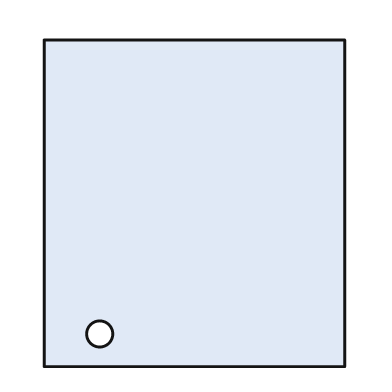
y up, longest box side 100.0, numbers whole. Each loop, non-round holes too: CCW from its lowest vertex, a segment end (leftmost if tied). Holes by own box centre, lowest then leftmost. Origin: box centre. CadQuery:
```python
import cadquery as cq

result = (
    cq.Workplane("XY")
    .moveTo(-46.0, -50.0)
    .lineTo(46.0, -50.0)
    .lineTo(46.0, 50.0)
    .lineTo(-46.0, 50.0)
    .close()
    .moveTo(-29.0, -40.0)
    .circle(4.0)
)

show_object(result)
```